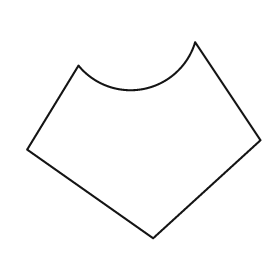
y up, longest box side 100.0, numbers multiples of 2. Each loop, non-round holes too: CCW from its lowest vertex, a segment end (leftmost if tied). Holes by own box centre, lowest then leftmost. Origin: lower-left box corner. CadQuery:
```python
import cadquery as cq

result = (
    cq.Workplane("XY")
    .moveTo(54.0, 0.0)
    .lineTo(100.0, 42.0)
    .lineTo(72.0, 84.0)
    .threePointArc((50.0, 64.0), (22.0, 74.0))
    .lineTo(0.0, 38.0)
    .close()
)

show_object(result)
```